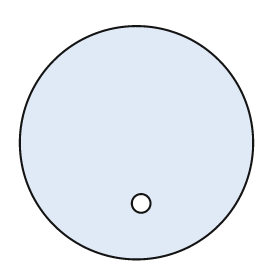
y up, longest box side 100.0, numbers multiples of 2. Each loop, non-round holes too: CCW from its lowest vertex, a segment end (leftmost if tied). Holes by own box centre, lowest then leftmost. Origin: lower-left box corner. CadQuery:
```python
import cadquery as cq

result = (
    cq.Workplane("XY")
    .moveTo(50.0, 50.0)
    .circle(50.0)
    .moveTo(52.0, 24.0)
    .circle(4.0)
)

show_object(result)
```